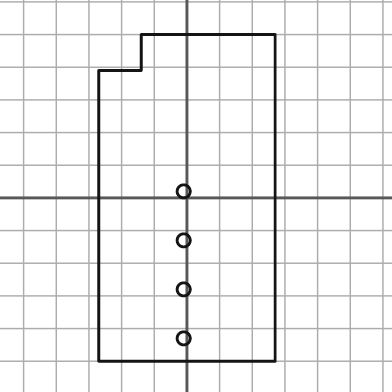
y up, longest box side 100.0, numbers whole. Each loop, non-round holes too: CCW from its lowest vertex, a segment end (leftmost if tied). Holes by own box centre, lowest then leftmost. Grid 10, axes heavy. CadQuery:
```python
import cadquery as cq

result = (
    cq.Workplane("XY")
    .moveTo(-27.0, -50.0)
    .lineTo(27.0, -50.0)
    .lineTo(27.0, 50.0)
    .lineTo(-14.0, 50.0)
    .lineTo(-14.0, 39.0)
    .lineTo(-27.0, 39.0)
    .close()
    .moveTo(-1.0, -43.0)
    .circle(2.0)
    .moveTo(-1.0, -28.0)
    .circle(2.0)
    .moveTo(-1.0, -13.0)
    .circle(2.0)
    .moveTo(-1.0, 2.0)
    .circle(2.0)
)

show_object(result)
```